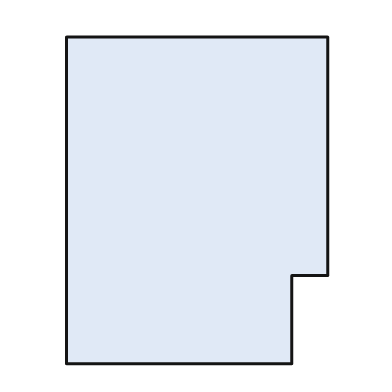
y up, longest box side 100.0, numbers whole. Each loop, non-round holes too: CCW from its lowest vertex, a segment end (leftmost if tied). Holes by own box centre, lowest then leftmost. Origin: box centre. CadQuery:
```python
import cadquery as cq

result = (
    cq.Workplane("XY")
    .moveTo(-40.0, -50.0)
    .lineTo(29.0, -50.0)
    .lineTo(29.0, -23.0)
    .lineTo(40.0, -23.0)
    .lineTo(40.0, 50.0)
    .lineTo(-40.0, 50.0)
    .close()
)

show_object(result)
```